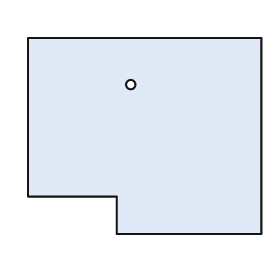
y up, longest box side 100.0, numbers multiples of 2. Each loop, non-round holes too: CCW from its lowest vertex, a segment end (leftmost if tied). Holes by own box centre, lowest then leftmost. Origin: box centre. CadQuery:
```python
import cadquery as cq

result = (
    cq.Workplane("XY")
    .moveTo(-12.0, -42.0)
    .lineTo(50.0, -42.0)
    .lineTo(50.0, 42.0)
    .lineTo(-50.0, 42.0)
    .lineTo(-50.0, -26.0)
    .lineTo(-12.0, -26.0)
    .close()
    .moveTo(-6.0, 22.0)
    .circle(2.0)
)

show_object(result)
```